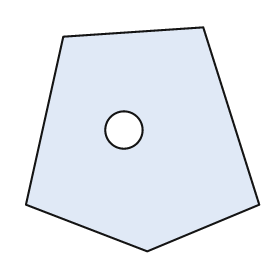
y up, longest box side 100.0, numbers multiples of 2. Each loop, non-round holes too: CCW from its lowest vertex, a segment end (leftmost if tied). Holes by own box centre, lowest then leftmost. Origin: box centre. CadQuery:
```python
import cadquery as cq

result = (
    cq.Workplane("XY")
    .moveTo(2.0, -48.0)
    .lineTo(50.0, -28.0)
    .lineTo(26.0, 48.0)
    .lineTo(-34.0, 44.0)
    .lineTo(-50.0, -28.0)
    .close()
    .moveTo(-8.0, 4.0)
    .circle(8.0)
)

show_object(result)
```